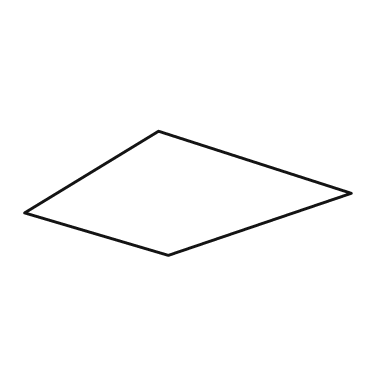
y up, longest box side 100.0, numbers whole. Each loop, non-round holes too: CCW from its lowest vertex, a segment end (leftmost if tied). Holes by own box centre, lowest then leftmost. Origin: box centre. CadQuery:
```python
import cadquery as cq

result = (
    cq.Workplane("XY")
    .moveTo(-6.0, -19.0)
    .lineTo(50.0, 0.0)
    .lineTo(-9.0, 19.0)
    .lineTo(-50.0, -6.0)
    .close()
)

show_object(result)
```